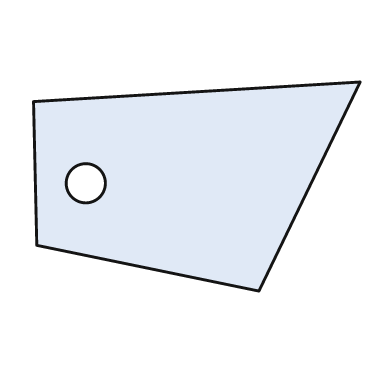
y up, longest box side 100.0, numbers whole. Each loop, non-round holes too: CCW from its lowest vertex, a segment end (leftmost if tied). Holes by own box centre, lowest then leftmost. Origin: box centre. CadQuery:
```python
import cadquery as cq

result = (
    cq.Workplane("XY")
    .moveTo(19.0, -32.0)
    .lineTo(50.0, 32.0)
    .lineTo(-50.0, 26.0)
    .lineTo(-49.0, -18.0)
    .close()
    .moveTo(-34.0, 1.0)
    .circle(6.0)
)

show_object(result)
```